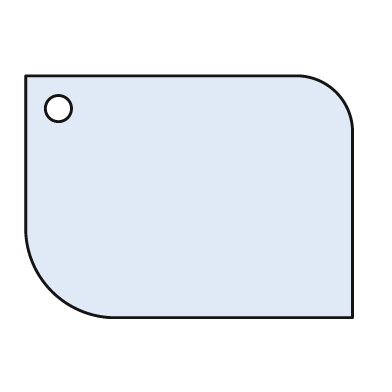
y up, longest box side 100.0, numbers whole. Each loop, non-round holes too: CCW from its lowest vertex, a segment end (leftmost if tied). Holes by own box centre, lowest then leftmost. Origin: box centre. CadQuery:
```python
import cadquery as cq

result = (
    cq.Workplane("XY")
    .moveTo(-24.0, -37.0)
    .lineTo(50.0, -37.0)
    .lineTo(50.0, 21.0)
    .threePointArc((45.0, 32.0), (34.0, 37.0))
    .lineTo(-50.0, 37.0)
    .lineTo(-50.0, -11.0)
    .threePointArc((-42.0, -29.0), (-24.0, -37.0))
    .close()
    .moveTo(-40.0, 27.0)
    .circle(4.0)
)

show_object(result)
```